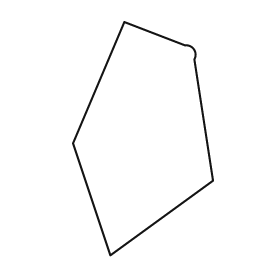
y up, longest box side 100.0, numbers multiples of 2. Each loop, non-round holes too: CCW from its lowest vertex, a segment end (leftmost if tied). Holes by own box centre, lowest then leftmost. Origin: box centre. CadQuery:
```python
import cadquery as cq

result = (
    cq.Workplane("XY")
    .moveTo(-14.0, -50.0)
    .lineTo(30.0, -18.0)
    .lineTo(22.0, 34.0)
    .threePointArc((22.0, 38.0), (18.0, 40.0))
    .lineTo(-8.0, 50.0)
    .lineTo(-30.0, -2.0)
    .close()
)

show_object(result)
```